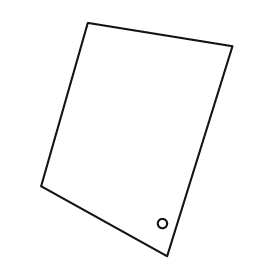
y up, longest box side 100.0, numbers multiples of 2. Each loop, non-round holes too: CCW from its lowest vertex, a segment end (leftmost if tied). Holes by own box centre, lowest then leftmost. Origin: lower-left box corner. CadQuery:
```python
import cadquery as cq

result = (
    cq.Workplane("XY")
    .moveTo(54.0, 0.0)
    .lineTo(82.0, 90.0)
    .lineTo(20.0, 100.0)
    .lineTo(0.0, 30.0)
    .close()
    .moveTo(52.0, 14.0)
    .circle(2.0)
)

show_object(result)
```